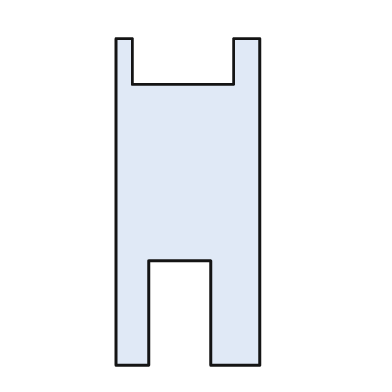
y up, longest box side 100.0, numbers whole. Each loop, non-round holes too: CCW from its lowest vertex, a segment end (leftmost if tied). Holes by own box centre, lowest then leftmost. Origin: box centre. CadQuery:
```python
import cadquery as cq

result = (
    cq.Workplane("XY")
    .moveTo(-22.0, -50.0)
    .lineTo(-12.0, -50.0)
    .lineTo(-12.0, -18.0)
    .lineTo(7.0, -18.0)
    .lineTo(7.0, -50.0)
    .lineTo(22.0, -50.0)
    .lineTo(22.0, 50.0)
    .lineTo(14.0, 50.0)
    .lineTo(14.0, 36.0)
    .lineTo(-17.0, 36.0)
    .lineTo(-17.0, 50.0)
    .lineTo(-22.0, 50.0)
    .close()
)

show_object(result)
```